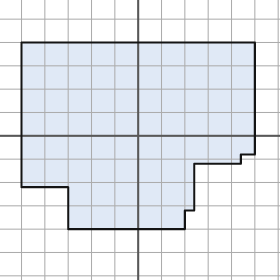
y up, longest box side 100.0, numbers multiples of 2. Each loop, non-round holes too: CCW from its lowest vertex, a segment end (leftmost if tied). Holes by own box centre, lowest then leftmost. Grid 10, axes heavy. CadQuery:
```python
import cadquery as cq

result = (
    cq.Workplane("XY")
    .moveTo(-30.0, -40.0)
    .lineTo(20.0, -40.0)
    .lineTo(20.0, -32.0)
    .lineTo(24.0, -32.0)
    .lineTo(24.0, -12.0)
    .lineTo(44.0, -12.0)
    .lineTo(44.0, -8.0)
    .lineTo(50.0, -8.0)
    .lineTo(50.0, 40.0)
    .lineTo(-50.0, 40.0)
    .lineTo(-50.0, -22.0)
    .lineTo(-30.0, -22.0)
    .close()
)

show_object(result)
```